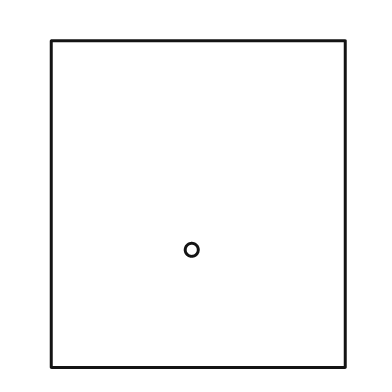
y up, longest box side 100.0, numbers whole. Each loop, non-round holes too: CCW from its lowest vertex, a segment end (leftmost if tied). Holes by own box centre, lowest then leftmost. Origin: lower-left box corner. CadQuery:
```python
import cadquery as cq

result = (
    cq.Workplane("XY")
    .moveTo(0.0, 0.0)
    .lineTo(90.0, 0.0)
    .lineTo(90.0, 100.0)
    .lineTo(0.0, 100.0)
    .close()
    .moveTo(43.0, 36.0)
    .circle(2.0)
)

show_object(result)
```